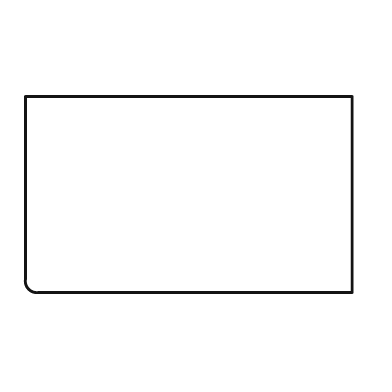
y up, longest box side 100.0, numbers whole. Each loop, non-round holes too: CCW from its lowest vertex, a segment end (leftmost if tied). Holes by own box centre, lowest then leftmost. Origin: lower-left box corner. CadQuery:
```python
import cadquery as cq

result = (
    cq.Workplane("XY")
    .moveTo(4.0, 0.0)
    .lineTo(100.0, 0.0)
    .lineTo(100.0, 60.0)
    .lineTo(0.0, 60.0)
    .lineTo(0.0, 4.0)
    .threePointArc((1.0, 1.0), (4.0, 0.0))
    .close()
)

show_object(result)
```